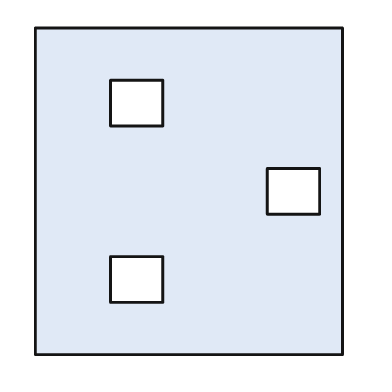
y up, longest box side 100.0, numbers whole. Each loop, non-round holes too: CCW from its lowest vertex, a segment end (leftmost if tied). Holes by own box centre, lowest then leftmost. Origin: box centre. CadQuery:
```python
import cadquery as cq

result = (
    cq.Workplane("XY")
    .moveTo(-47.0, -50.0)
    .lineTo(47.0, -50.0)
    .lineTo(47.0, 50.0)
    .lineTo(-47.0, 50.0)
    .close()
    .moveTo(-24.0, -34.0)
    .lineTo(-8.0, -34.0)
    .lineTo(-8.0, -20.0)
    .lineTo(-24.0, -20.0)
    .close()
    .moveTo(24.0, -7.0)
    .lineTo(40.0, -7.0)
    .lineTo(40.0, 7.0)
    .lineTo(24.0, 7.0)
    .close()
    .moveTo(-24.0, 20.0)
    .lineTo(-8.0, 20.0)
    .lineTo(-8.0, 34.0)
    .lineTo(-24.0, 34.0)
    .close()
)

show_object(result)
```